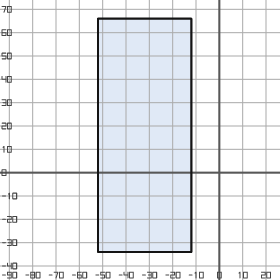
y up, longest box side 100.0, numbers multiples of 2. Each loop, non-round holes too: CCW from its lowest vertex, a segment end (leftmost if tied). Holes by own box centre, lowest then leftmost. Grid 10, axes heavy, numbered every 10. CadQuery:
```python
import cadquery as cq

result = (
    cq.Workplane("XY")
    .moveTo(-52.0, -34.0)
    .lineTo(-12.0, -34.0)
    .lineTo(-12.0, 66.0)
    .lineTo(-52.0, 66.0)
    .close()
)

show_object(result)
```